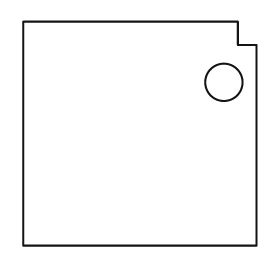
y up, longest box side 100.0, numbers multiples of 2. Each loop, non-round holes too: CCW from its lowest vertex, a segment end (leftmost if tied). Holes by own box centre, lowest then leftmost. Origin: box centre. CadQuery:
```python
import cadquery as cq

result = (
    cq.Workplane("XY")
    .moveTo(-50.0, -48.0)
    .lineTo(50.0, -48.0)
    .lineTo(50.0, 38.0)
    .lineTo(42.0, 38.0)
    .lineTo(42.0, 48.0)
    .lineTo(-50.0, 48.0)
    .close()
    .moveTo(36.0, 22.0)
    .circle(8.0)
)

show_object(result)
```